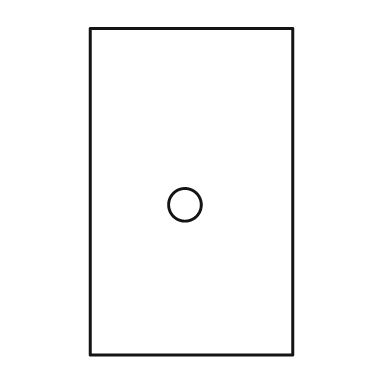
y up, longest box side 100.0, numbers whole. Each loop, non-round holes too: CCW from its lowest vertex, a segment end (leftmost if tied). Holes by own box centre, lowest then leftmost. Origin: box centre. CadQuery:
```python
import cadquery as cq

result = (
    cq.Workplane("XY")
    .moveTo(-31.0, -50.0)
    .lineTo(31.0, -50.0)
    .lineTo(31.0, 50.0)
    .lineTo(-31.0, 50.0)
    .close()
    .moveTo(-2.0, -4.0)
    .circle(5.0)
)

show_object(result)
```